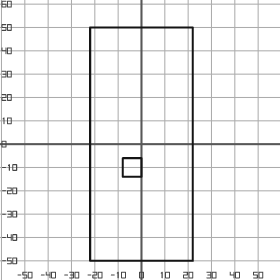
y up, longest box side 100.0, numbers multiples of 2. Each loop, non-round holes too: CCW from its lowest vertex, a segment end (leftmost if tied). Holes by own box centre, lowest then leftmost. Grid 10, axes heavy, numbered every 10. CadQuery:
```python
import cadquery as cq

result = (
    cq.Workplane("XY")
    .moveTo(-22.0, -50.0)
    .lineTo(22.0, -50.0)
    .lineTo(22.0, 50.0)
    .lineTo(-22.0, 50.0)
    .close()
    .moveTo(-8.0, -14.0)
    .lineTo(0.0, -14.0)
    .lineTo(0.0, -6.0)
    .lineTo(-8.0, -6.0)
    .close()
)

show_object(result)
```